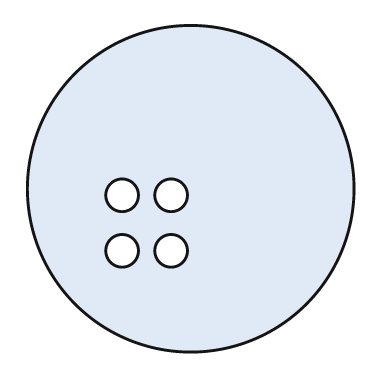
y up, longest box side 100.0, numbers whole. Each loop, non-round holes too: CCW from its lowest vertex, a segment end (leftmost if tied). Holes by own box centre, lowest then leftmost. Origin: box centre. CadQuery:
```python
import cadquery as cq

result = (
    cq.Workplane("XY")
    .moveTo(0.0, 0.0)
    .circle(50.0)
    .moveTo(-21.0, -19.0)
    .circle(5.0)
    .moveTo(-6.0, -19.0)
    .circle(5.0)
    .moveTo(-21.0, -2.0)
    .circle(5.0)
    .moveTo(-6.0, -2.0)
    .circle(5.0)
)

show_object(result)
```